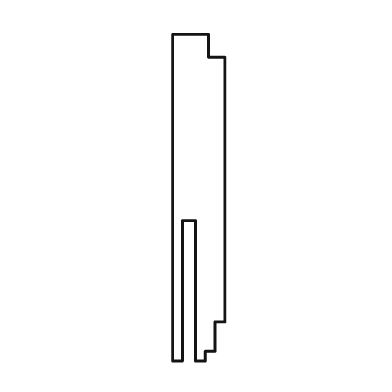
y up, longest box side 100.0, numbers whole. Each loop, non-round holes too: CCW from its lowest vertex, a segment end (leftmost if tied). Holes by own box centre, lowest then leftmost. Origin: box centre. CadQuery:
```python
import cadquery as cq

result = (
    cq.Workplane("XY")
    .moveTo(-8.0, -50.0)
    .lineTo(-5.0, -50.0)
    .lineTo(-5.0, -7.0)
    .lineTo(-1.0, -7.0)
    .lineTo(-1.0, -50.0)
    .lineTo(2.0, -50.0)
    .lineTo(2.0, -47.0)
    .lineTo(5.0, -47.0)
    .lineTo(5.0, -38.0)
    .lineTo(8.0, -38.0)
    .lineTo(8.0, 43.0)
    .lineTo(3.0, 43.0)
    .lineTo(3.0, 50.0)
    .lineTo(-8.0, 50.0)
    .close()
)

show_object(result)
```